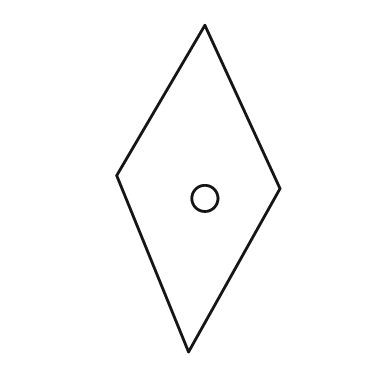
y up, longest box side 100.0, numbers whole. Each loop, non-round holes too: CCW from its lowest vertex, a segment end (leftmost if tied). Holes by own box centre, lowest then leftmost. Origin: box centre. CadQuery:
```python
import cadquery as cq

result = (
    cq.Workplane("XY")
    .moveTo(-3.0, -50.0)
    .lineTo(25.0, 0.0)
    .lineTo(2.0, 50.0)
    .lineTo(-25.0, 4.0)
    .close()
    .moveTo(2.0, -3.0)
    .circle(4.0)
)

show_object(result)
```